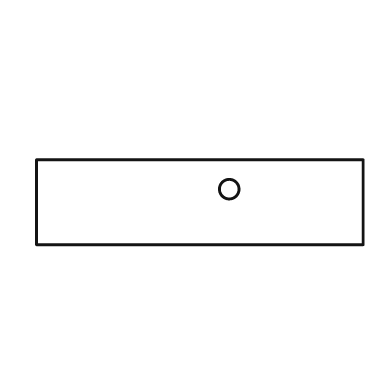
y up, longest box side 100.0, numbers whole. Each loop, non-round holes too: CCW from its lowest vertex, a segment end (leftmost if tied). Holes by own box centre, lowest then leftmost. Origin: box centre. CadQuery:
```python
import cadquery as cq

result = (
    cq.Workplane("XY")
    .moveTo(-50.0, -13.0)
    .lineTo(50.0, -13.0)
    .lineTo(50.0, 13.0)
    .lineTo(-50.0, 13.0)
    .close()
    .moveTo(9.0, 4.0)
    .circle(3.0)
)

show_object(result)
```